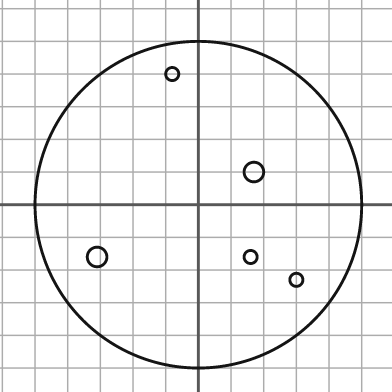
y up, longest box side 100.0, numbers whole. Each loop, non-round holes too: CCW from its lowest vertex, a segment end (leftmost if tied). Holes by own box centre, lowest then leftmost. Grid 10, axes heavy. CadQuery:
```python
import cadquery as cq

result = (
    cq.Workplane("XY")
    .moveTo(0.0, 0.0)
    .circle(50.0)
    .moveTo(30.0, -23.0)
    .circle(2.0)
    .moveTo(-31.0, -16.0)
    .circle(3.0)
    .moveTo(16.0, -16.0)
    .circle(2.0)
    .moveTo(17.0, 10.0)
    .circle(3.0)
    .moveTo(-8.0, 40.0)
    .circle(2.0)
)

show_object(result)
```